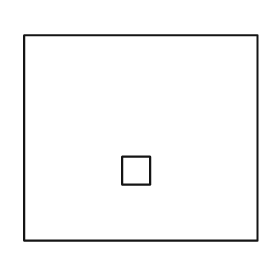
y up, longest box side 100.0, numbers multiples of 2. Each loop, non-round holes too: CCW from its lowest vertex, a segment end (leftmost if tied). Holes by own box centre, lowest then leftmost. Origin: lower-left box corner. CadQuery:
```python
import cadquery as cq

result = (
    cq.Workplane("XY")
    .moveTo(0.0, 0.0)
    .lineTo(100.0, 0.0)
    .lineTo(100.0, 88.0)
    .lineTo(0.0, 88.0)
    .close()
    .moveTo(42.0, 24.0)
    .lineTo(54.0, 24.0)
    .lineTo(54.0, 36.0)
    .lineTo(42.0, 36.0)
    .close()
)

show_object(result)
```